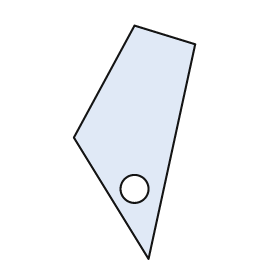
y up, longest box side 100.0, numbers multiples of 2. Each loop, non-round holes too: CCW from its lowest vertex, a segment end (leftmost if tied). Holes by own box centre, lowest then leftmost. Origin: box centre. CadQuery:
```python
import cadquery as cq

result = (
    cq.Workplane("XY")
    .moveTo(6.0, -50.0)
    .lineTo(26.0, 42.0)
    .lineTo(0.0, 50.0)
    .lineTo(-26.0, 2.0)
    .close()
    .moveTo(0.0, -20.0)
    .circle(6.0)
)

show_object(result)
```